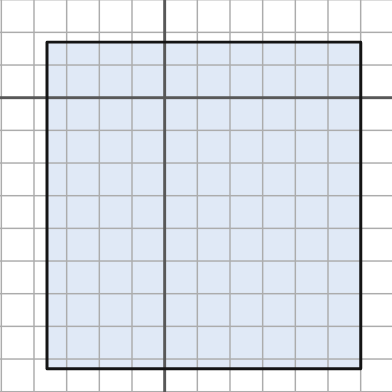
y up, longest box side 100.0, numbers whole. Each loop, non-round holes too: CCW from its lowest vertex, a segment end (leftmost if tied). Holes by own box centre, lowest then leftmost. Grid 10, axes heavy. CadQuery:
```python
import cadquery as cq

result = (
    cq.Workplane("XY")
    .moveTo(-36.0, -83.0)
    .lineTo(60.0, -83.0)
    .lineTo(60.0, 17.0)
    .lineTo(-36.0, 17.0)
    .close()
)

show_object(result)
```